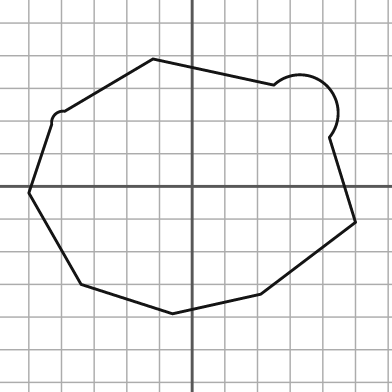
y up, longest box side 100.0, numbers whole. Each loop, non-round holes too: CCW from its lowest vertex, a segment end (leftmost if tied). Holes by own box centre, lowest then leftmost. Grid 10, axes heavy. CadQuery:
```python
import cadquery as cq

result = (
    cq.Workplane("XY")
    .moveTo(-6.0, -39.0)
    .lineTo(21.0, -33.0)
    .lineTo(50.0, -11.0)
    .lineTo(42.0, 15.0)
    .threePointArc((41.0, 31.0), (25.0, 31.0))
    .lineTo(-12.0, 39.0)
    .lineTo(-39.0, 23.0)
    .threePointArc((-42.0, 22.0), (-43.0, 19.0))
    .lineTo(-50.0, -2.0)
    .lineTo(-34.0, -30.0)
    .close()
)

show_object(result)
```